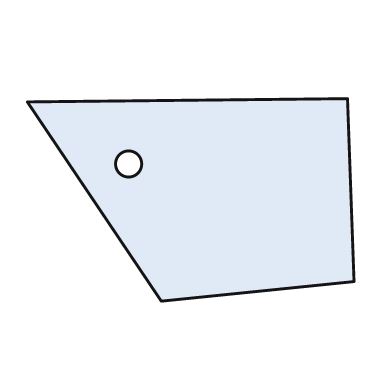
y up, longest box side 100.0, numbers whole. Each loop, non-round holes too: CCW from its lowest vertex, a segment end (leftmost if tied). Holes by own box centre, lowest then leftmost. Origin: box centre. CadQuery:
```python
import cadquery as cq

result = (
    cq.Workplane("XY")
    .moveTo(-9.0, -31.0)
    .lineTo(50.0, -25.0)
    .lineTo(48.0, 31.0)
    .lineTo(-50.0, 30.0)
    .close()
    .moveTo(-19.0, 11.0)
    .circle(4.0)
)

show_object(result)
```